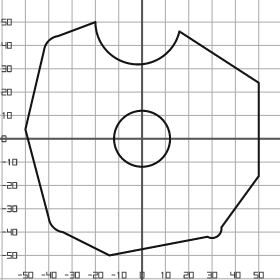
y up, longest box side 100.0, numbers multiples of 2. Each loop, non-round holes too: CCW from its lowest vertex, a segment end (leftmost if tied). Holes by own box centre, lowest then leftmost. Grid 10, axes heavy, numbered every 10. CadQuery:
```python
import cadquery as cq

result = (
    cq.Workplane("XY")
    .moveTo(-14.0, -50.0)
    .lineTo(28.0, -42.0)
    .threePointArc((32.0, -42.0), (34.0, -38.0))
    .lineTo(50.0, -16.0)
    .lineTo(50.0, 24.0)
    .lineTo(16.0, 46.0)
    .threePointArc((-4.0, 32.0), (-20.0, 50.0))
    .lineTo(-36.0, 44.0)
    .threePointArc((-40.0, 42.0), (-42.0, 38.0))
    .lineTo(-50.0, 4.0)
    .lineTo(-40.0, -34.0)
    .threePointArc((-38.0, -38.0), (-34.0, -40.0))
    .close()
    .moveTo(0.0, 0.0)
    .circle(12.0)
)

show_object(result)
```